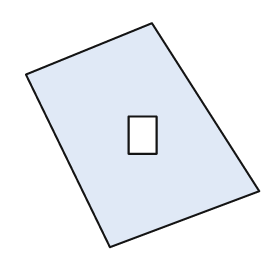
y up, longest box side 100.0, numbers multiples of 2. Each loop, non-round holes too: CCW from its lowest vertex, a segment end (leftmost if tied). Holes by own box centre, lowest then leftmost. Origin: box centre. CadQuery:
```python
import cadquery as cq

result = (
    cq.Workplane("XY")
    .moveTo(-14.0, -48.0)
    .lineTo(50.0, -24.0)
    .lineTo(4.0, 48.0)
    .lineTo(-50.0, 26.0)
    .close()
    .moveTo(-6.0, -8.0)
    .lineTo(6.0, -8.0)
    .lineTo(6.0, 8.0)
    .lineTo(-6.0, 8.0)
    .close()
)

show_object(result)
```